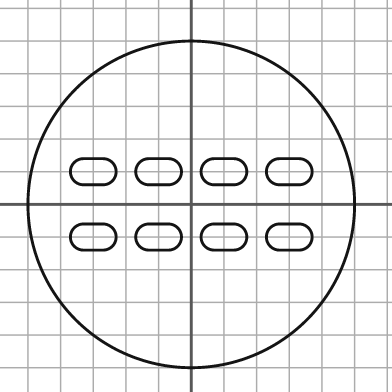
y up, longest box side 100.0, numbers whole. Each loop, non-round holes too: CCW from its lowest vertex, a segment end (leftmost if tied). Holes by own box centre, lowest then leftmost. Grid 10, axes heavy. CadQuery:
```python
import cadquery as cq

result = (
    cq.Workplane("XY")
    .moveTo(0.0, 0.0)
    .circle(50.0)
    .moveTo(-33.0, -14.0)
    .lineTo(-27.0, -14.0)
    .threePointArc((-23.0, -10.0), (-27.0, -6.0))
    .lineTo(-33.0, -6.0)
    .threePointArc((-37.0, -10.0), (-33.0, -14.0))
    .close()
    .moveTo(-13.0, -14.0)
    .lineTo(-7.0, -14.0)
    .threePointArc((-3.0, -10.0), (-7.0, -6.0))
    .lineTo(-13.0, -6.0)
    .threePointArc((-17.0, -10.0), (-13.0, -14.0))
    .close()
    .moveTo(7.0, -14.0)
    .lineTo(13.0, -14.0)
    .threePointArc((17.0, -10.0), (13.0, -6.0))
    .lineTo(7.0, -6.0)
    .threePointArc((3.0, -10.0), (7.0, -14.0))
    .close()
    .moveTo(27.0, -14.0)
    .lineTo(33.0, -14.0)
    .threePointArc((37.0, -10.0), (33.0, -6.0))
    .lineTo(27.0, -6.0)
    .threePointArc((23.0, -10.0), (27.0, -14.0))
    .close()
    .moveTo(-33.0, 6.0)
    .lineTo(-27.0, 6.0)
    .threePointArc((-23.0, 10.0), (-27.0, 14.0))
    .lineTo(-33.0, 14.0)
    .threePointArc((-37.0, 10.0), (-33.0, 6.0))
    .close()
    .moveTo(-13.0, 6.0)
    .lineTo(-7.0, 6.0)
    .threePointArc((-3.0, 10.0), (-7.0, 14.0))
    .lineTo(-13.0, 14.0)
    .threePointArc((-17.0, 10.0), (-13.0, 6.0))
    .close()
    .moveTo(7.0, 6.0)
    .lineTo(13.0, 6.0)
    .threePointArc((17.0, 10.0), (13.0, 14.0))
    .lineTo(7.0, 14.0)
    .threePointArc((3.0, 10.0), (7.0, 6.0))
    .close()
    .moveTo(27.0, 6.0)
    .lineTo(33.0, 6.0)
    .threePointArc((37.0, 10.0), (33.0, 14.0))
    .lineTo(27.0, 14.0)
    .threePointArc((23.0, 10.0), (27.0, 6.0))
    .close()
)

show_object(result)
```